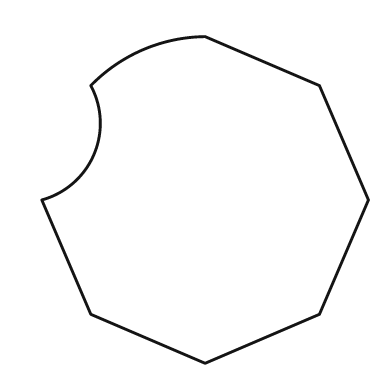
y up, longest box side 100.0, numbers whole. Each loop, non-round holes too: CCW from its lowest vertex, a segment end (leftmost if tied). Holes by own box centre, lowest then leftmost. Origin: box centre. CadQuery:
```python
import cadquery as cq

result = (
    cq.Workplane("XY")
    .moveTo(0.0, -50.0)
    .lineTo(35.0, -35.0)
    .lineTo(50.0, 0.0)
    .lineTo(35.0, 35.0)
    .lineTo(0.0, 50.0)
    .threePointArc((-19.0, 46.0), (-35.0, 35.0))
    .threePointArc((-34.0, 14.0), (-50.0, 0.0))
    .lineTo(-35.0, -35.0)
    .close()
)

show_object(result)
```